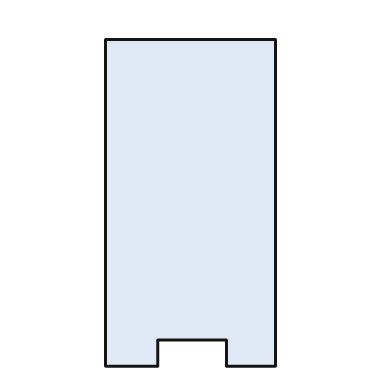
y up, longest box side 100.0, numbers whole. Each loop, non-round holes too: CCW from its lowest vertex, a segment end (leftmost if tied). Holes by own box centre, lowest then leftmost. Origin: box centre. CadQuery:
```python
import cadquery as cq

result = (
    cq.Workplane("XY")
    .moveTo(-26.0, -50.0)
    .lineTo(-10.0, -50.0)
    .lineTo(-10.0, -42.0)
    .lineTo(11.0, -42.0)
    .lineTo(11.0, -50.0)
    .lineTo(26.0, -50.0)
    .lineTo(26.0, 50.0)
    .lineTo(-26.0, 50.0)
    .close()
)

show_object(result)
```